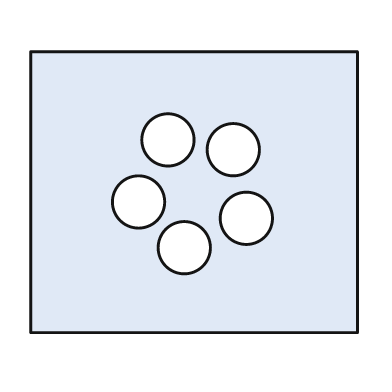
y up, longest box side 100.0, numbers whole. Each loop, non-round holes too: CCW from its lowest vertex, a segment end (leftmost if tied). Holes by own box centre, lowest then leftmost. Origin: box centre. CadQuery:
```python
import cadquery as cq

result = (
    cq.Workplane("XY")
    .moveTo(-50.0, -43.0)
    .lineTo(50.0, -43.0)
    .lineTo(50.0, 43.0)
    .lineTo(-50.0, 43.0)
    .close()
    .moveTo(-3.0, -17.0)
    .circle(8.0)
    .moveTo(16.0, -8.0)
    .circle(8.0)
    .moveTo(-17.0, -3.0)
    .circle(8.0)
    .moveTo(12.0, 13.0)
    .circle(8.0)
    .moveTo(-8.0, 16.0)
    .circle(8.0)
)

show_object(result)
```